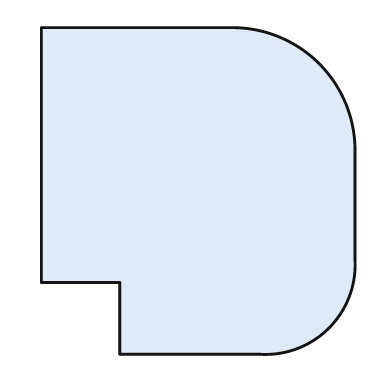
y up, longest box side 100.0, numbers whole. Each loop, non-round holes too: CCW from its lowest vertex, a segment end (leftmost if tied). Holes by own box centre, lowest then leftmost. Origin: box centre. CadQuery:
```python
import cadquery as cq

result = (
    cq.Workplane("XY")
    .moveTo(-24.0, -50.0)
    .lineTo(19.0, -50.0)
    .threePointArc((40.0, -42.0), (48.0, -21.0))
    .lineTo(48.0, 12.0)
    .threePointArc((37.0, 39.0), (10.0, 50.0))
    .lineTo(-48.0, 50.0)
    .lineTo(-48.0, -28.0)
    .lineTo(-24.0, -28.0)
    .close()
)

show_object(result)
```